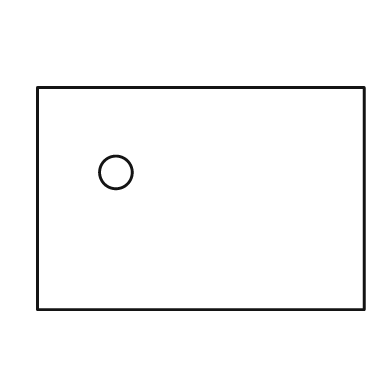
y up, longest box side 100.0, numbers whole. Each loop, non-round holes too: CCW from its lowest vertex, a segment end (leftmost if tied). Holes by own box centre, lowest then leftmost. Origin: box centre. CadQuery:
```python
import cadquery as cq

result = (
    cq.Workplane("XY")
    .moveTo(-50.0, -34.0)
    .lineTo(50.0, -34.0)
    .lineTo(50.0, 34.0)
    .lineTo(-50.0, 34.0)
    .close()
    .moveTo(-26.0, 8.0)
    .circle(5.0)
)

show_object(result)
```